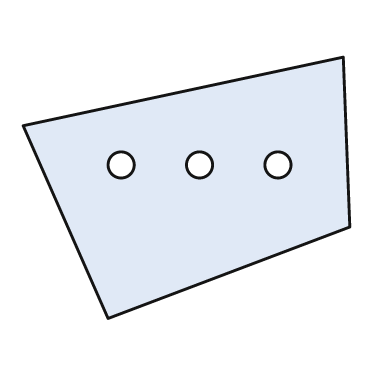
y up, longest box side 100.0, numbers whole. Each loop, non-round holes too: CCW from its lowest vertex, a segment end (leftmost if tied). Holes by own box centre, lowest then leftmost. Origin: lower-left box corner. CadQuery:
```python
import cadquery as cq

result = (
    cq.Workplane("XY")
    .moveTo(26.0, 0.0)
    .lineTo(100.0, 28.0)
    .lineTo(98.0, 80.0)
    .lineTo(0.0, 59.0)
    .close()
    .moveTo(30.0, 47.0)
    .circle(4.0)
    .moveTo(54.0, 47.0)
    .circle(4.0)
    .moveTo(78.0, 47.0)
    .circle(4.0)
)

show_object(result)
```